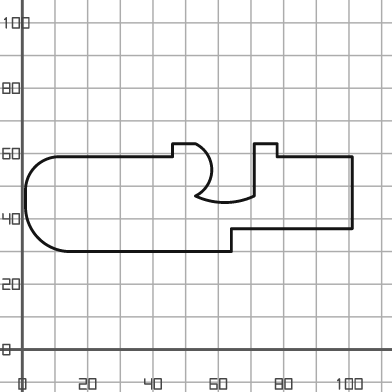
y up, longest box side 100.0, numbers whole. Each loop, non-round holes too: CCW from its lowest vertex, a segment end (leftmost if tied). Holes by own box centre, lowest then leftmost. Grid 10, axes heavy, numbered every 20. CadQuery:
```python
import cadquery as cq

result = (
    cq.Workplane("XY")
    .moveTo(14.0, 30.0)
    .lineTo(64.0, 30.0)
    .lineTo(64.0, 37.0)
    .lineTo(101.0, 37.0)
    .lineTo(101.0, 59.0)
    .lineTo(78.0, 59.0)
    .lineTo(78.0, 63.0)
    .lineTo(71.0, 63.0)
    .lineTo(71.0, 47.0)
    .threePointArc((62.0, 45.0), (53.0, 47.0))
    .threePointArc((58.0, 55.0), (53.0, 63.0))
    .lineTo(46.0, 63.0)
    .lineTo(46.0, 59.0)
    .lineTo(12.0, 59.0)
    .threePointArc((4.0, 56.0), (1.0, 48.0))
    .lineTo(1.0, 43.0)
    .threePointArc((5.0, 34.0), (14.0, 30.0))
    .close()
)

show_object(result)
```